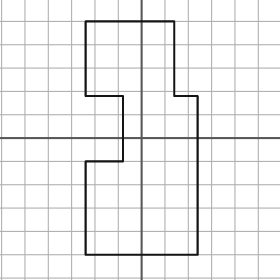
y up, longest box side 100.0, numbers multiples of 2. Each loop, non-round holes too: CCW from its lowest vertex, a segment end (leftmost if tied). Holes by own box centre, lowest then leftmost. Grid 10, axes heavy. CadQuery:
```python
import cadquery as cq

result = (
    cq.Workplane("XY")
    .moveTo(-24.0, -50.0)
    .lineTo(24.0, -50.0)
    .lineTo(24.0, 18.0)
    .lineTo(14.0, 18.0)
    .lineTo(14.0, 50.0)
    .lineTo(-24.0, 50.0)
    .lineTo(-24.0, 18.0)
    .lineTo(-8.0, 18.0)
    .lineTo(-8.0, -10.0)
    .lineTo(-24.0, -10.0)
    .close()
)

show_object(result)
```